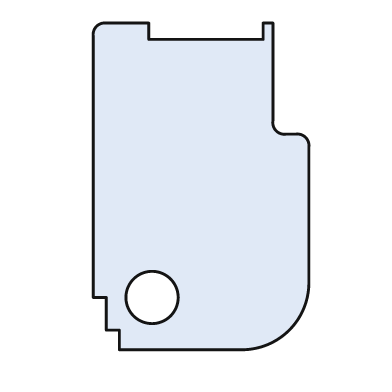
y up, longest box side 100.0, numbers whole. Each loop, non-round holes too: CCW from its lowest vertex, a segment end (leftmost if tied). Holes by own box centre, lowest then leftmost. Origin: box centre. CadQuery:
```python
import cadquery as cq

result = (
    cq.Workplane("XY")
    .moveTo(-25.0, -50.0)
    .lineTo(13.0, -50.0)
    .threePointArc((27.0, -44.0), (33.0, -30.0))
    .lineTo(33.0, 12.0)
    .threePointArc((32.0, 15.0), (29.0, 16.0))
    .lineTo(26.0, 16.0)
    .threePointArc((23.0, 17.0), (22.0, 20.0))
    .lineTo(22.0, 50.0)
    .lineTo(19.0, 50.0)
    .lineTo(19.0, 45.0)
    .lineTo(-16.0, 45.0)
    .lineTo(-16.0, 50.0)
    .lineTo(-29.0, 50.0)
    .threePointArc((-32.0, 49.0), (-33.0, 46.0))
    .lineTo(-33.0, -34.0)
    .lineTo(-29.0, -34.0)
    .lineTo(-29.0, -44.0)
    .lineTo(-25.0, -44.0)
    .close()
    .moveTo(-15.0, -34.0)
    .circle(8.0)
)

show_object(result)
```